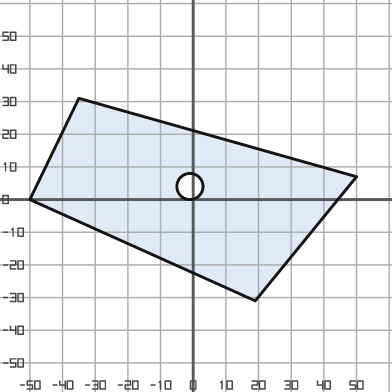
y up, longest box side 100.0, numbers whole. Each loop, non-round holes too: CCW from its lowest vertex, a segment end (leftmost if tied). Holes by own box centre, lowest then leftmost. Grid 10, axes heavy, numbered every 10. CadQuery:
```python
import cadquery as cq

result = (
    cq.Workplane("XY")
    .moveTo(19.0, -31.0)
    .lineTo(50.0, 7.0)
    .lineTo(-35.0, 31.0)
    .lineTo(-50.0, 0.0)
    .close()
    .moveTo(-1.0, 4.0)
    .circle(4.0)
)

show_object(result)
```